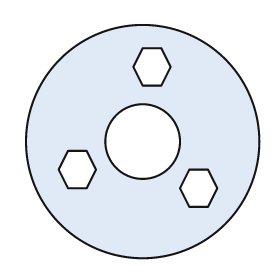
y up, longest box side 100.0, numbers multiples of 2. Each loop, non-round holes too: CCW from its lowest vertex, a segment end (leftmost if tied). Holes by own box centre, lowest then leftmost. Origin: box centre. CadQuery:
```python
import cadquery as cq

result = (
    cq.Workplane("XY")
    .moveTo(0.0, 0.0)
    .circle(50.0)
    .moveTo(20.0, -28.0)
    .lineTo(28.0, -28.0)
    .lineTo(32.0, -20.0)
    .lineTo(28.0, -12.0)
    .lineTo(20.0, -12.0)
    .lineTo(16.0, -20.0)
    .close()
    .moveTo(-32.0, -20.0)
    .lineTo(-24.0, -20.0)
    .lineTo(-20.0, -12.0)
    .lineTo(-24.0, -4.0)
    .lineTo(-32.0, -4.0)
    .lineTo(-36.0, -12.0)
    .close()
    .moveTo(0.0, 0.0)
    .circle(16.0)
    .moveTo(0.0, 24.0)
    .lineTo(8.0, 24.0)
    .lineTo(12.0, 32.0)
    .lineTo(8.0, 40.0)
    .lineTo(0.0, 40.0)
    .lineTo(-4.0, 32.0)
    .close()
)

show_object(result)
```